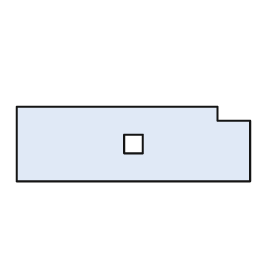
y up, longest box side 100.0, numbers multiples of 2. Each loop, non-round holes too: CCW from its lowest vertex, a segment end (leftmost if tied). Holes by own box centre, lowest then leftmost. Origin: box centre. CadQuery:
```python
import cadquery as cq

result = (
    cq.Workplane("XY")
    .moveTo(-50.0, -16.0)
    .lineTo(50.0, -16.0)
    .lineTo(50.0, 10.0)
    .lineTo(36.0, 10.0)
    .lineTo(36.0, 16.0)
    .lineTo(-50.0, 16.0)
    .close()
    .moveTo(-4.0, -4.0)
    .lineTo(4.0, -4.0)
    .lineTo(4.0, 4.0)
    .lineTo(-4.0, 4.0)
    .close()
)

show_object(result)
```